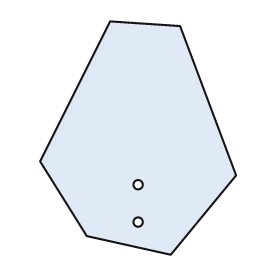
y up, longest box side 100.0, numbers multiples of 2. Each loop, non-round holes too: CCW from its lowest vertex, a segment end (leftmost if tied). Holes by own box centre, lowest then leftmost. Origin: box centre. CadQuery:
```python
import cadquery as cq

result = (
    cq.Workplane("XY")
    .moveTo(14.0, -50.0)
    .lineTo(42.0, -16.0)
    .lineTo(18.0, 48.0)
    .lineTo(-12.0, 50.0)
    .lineTo(-42.0, -10.0)
    .lineTo(-22.0, -42.0)
    .close()
    .moveTo(0.0, -36.0)
    .circle(2.0)
    .moveTo(0.0, -20.0)
    .circle(2.0)
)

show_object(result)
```